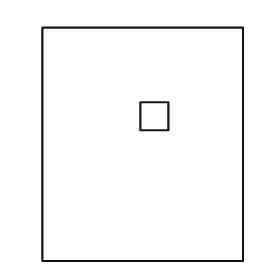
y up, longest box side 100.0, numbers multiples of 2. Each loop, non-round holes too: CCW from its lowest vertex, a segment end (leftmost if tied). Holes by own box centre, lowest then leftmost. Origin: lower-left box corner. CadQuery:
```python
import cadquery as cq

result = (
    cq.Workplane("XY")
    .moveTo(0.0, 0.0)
    .lineTo(86.0, 0.0)
    .lineTo(86.0, 100.0)
    .lineTo(0.0, 100.0)
    .close()
    .moveTo(42.0, 56.0)
    .lineTo(54.0, 56.0)
    .lineTo(54.0, 68.0)
    .lineTo(42.0, 68.0)
    .close()
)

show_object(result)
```